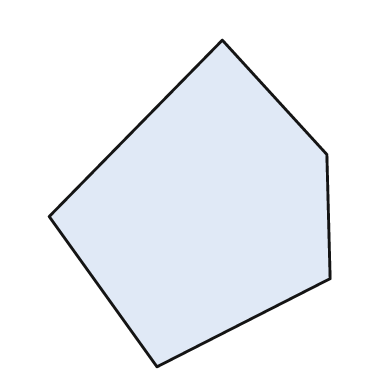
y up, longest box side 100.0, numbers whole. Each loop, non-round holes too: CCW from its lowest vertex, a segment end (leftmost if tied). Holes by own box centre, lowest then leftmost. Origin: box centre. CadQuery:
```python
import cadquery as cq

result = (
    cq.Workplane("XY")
    .moveTo(-10.0, -50.0)
    .lineTo(43.0, -23.0)
    .lineTo(42.0, 15.0)
    .lineTo(10.0, 50.0)
    .lineTo(-43.0, -4.0)
    .close()
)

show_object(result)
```